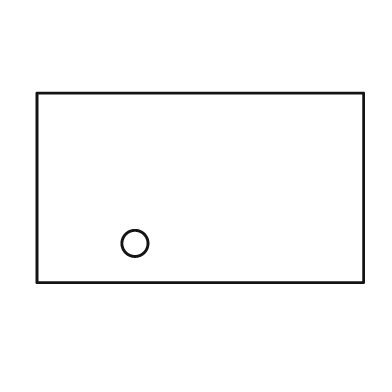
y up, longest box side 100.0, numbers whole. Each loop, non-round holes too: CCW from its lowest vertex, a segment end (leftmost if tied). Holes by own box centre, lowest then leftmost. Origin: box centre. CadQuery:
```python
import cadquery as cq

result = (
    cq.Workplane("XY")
    .moveTo(-50.0, -29.0)
    .lineTo(50.0, -29.0)
    .lineTo(50.0, 29.0)
    .lineTo(-50.0, 29.0)
    .close()
    .moveTo(-20.0, -17.0)
    .circle(4.0)
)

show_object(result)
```